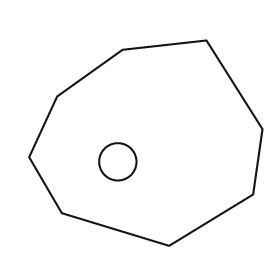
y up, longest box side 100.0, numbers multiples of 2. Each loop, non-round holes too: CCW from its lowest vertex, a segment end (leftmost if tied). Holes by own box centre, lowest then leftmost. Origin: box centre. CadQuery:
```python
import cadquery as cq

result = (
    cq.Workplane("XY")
    .moveTo(10.0, -44.0)
    .lineTo(46.0, -22.0)
    .lineTo(50.0, 6.0)
    .lineTo(26.0, 44.0)
    .lineTo(-10.0, 40.0)
    .lineTo(-38.0, 20.0)
    .lineTo(-50.0, -6.0)
    .lineTo(-36.0, -30.0)
    .close()
    .moveTo(-12.0, -8.0)
    .circle(8.0)
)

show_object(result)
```